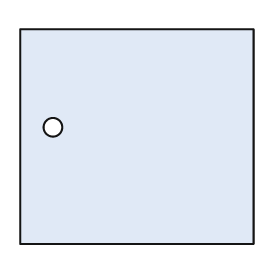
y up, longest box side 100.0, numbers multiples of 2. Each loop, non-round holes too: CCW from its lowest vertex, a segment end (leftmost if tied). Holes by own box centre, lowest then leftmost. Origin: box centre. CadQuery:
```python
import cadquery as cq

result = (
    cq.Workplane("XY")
    .moveTo(-50.0, -46.0)
    .lineTo(50.0, -46.0)
    .lineTo(50.0, 46.0)
    .lineTo(-50.0, 46.0)
    .close()
    .moveTo(-36.0, 4.0)
    .circle(4.0)
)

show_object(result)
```